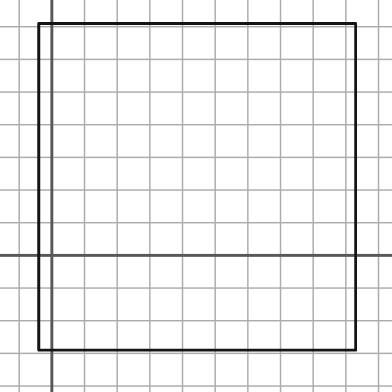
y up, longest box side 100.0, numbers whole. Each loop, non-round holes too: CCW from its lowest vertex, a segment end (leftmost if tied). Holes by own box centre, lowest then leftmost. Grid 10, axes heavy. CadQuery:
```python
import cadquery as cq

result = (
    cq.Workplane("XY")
    .moveTo(-4.0, -29.0)
    .lineTo(93.0, -29.0)
    .lineTo(93.0, 71.0)
    .lineTo(-4.0, 71.0)
    .close()
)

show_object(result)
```